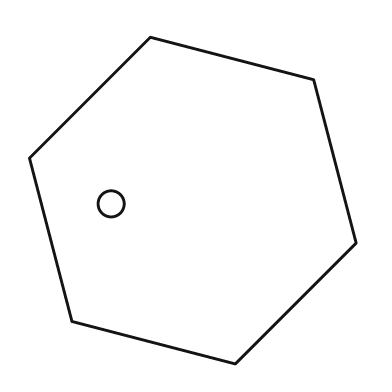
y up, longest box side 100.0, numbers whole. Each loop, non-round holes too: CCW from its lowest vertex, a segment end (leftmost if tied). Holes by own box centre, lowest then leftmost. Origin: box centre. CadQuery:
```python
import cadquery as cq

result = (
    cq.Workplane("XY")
    .moveTo(13.0, -50.0)
    .lineTo(50.0, -13.0)
    .lineTo(37.0, 37.0)
    .lineTo(-13.0, 50.0)
    .lineTo(-50.0, 13.0)
    .lineTo(-37.0, -37.0)
    .close()
    .moveTo(-25.0, -1.0)
    .circle(4.0)
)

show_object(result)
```